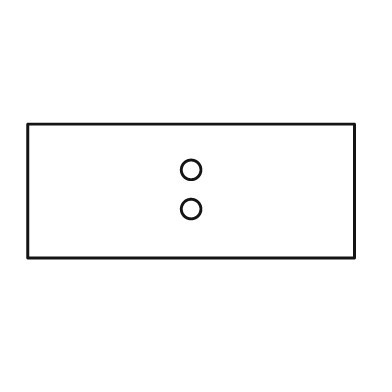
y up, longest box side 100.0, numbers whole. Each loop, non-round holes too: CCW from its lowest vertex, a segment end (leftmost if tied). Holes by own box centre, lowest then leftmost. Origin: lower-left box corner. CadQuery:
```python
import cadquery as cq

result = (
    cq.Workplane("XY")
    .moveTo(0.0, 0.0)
    .lineTo(100.0, 0.0)
    .lineTo(100.0, 41.0)
    .lineTo(0.0, 41.0)
    .close()
    .moveTo(50.0, 15.0)
    .circle(3.0)
    .moveTo(50.0, 27.0)
    .circle(3.0)
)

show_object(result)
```